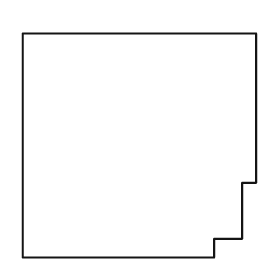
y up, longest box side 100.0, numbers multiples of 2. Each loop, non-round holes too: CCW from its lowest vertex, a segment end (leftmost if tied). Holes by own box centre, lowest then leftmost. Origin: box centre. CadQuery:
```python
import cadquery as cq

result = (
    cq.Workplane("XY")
    .moveTo(-50.0, -48.0)
    .lineTo(32.0, -48.0)
    .lineTo(32.0, -40.0)
    .lineTo(44.0, -40.0)
    .lineTo(44.0, -16.0)
    .lineTo(50.0, -16.0)
    .lineTo(50.0, 48.0)
    .lineTo(-50.0, 48.0)
    .close()
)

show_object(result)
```